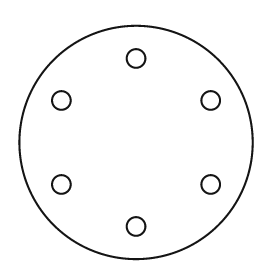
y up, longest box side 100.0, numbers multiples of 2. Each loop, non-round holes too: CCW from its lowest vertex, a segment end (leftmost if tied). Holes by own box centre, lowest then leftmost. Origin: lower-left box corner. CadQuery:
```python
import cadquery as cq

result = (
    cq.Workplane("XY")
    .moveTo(50.0, 50.0)
    .circle(50.0)
    .moveTo(50.0, 14.0)
    .circle(4.0)
    .moveTo(18.0, 32.0)
    .circle(4.0)
    .moveTo(82.0, 32.0)
    .circle(4.0)
    .moveTo(18.0, 68.0)
    .circle(4.0)
    .moveTo(82.0, 68.0)
    .circle(4.0)
    .moveTo(50.0, 86.0)
    .circle(4.0)
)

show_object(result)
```